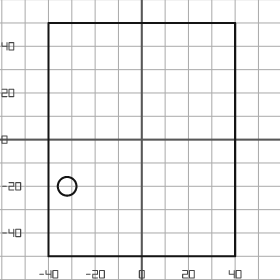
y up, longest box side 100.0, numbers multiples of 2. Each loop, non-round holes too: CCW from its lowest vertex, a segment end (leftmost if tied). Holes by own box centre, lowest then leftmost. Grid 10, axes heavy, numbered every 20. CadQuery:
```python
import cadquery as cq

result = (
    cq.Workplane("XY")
    .moveTo(-40.0, -50.0)
    .lineTo(40.0, -50.0)
    .lineTo(40.0, 50.0)
    .lineTo(-40.0, 50.0)
    .close()
    .moveTo(-32.0, -20.0)
    .circle(4.0)
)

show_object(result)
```